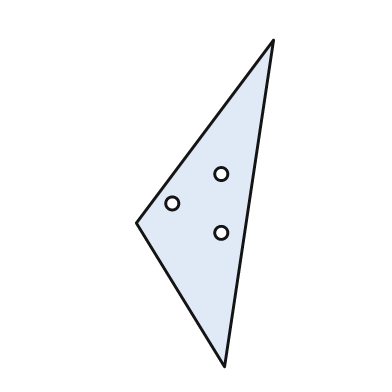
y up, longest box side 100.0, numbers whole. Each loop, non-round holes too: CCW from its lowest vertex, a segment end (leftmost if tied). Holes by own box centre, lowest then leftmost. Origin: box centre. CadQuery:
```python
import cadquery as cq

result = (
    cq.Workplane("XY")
    .moveTo(6.0, -50.0)
    .lineTo(21.0, 50.0)
    .lineTo(-21.0, -6.0)
    .close()
    .moveTo(5.0, -9.0)
    .circle(2.0)
    .moveTo(-10.0, 0.0)
    .circle(2.0)
    .moveTo(5.0, 9.0)
    .circle(2.0)
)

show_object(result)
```